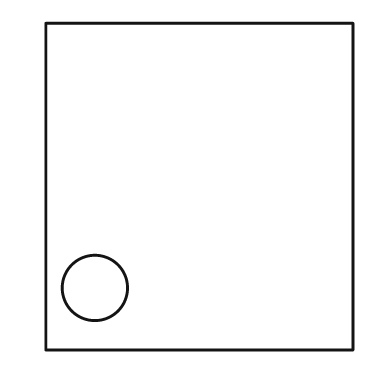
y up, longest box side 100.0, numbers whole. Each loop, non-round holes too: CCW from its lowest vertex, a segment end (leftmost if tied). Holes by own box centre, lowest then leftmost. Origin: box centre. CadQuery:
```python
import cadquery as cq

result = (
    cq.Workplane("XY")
    .moveTo(-47.0, -50.0)
    .lineTo(47.0, -50.0)
    .lineTo(47.0, 50.0)
    .lineTo(-47.0, 50.0)
    .close()
    .moveTo(-32.0, -31.0)
    .circle(10.0)
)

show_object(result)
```